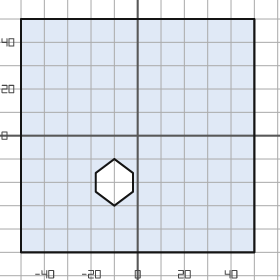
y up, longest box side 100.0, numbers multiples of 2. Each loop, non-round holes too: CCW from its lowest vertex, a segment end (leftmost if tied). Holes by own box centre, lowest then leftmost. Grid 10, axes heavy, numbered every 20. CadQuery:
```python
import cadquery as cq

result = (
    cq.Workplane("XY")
    .moveTo(-50.0, -50.0)
    .lineTo(50.0, -50.0)
    .lineTo(50.0, 50.0)
    .lineTo(-50.0, 50.0)
    .close()
    .moveTo(-10.0, -30.0)
    .lineTo(-2.0, -24.0)
    .lineTo(-2.0, -16.0)
    .lineTo(-10.0, -10.0)
    .lineTo(-18.0, -16.0)
    .lineTo(-18.0, -24.0)
    .close()
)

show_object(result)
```